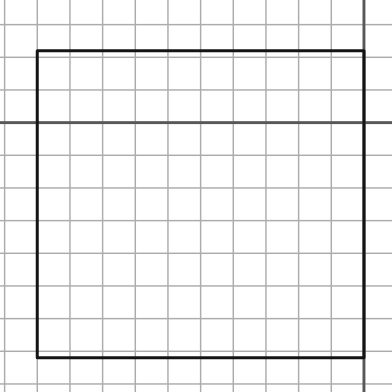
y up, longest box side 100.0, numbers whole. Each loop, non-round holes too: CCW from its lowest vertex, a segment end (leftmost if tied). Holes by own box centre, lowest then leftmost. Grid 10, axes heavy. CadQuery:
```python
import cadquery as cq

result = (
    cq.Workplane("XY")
    .moveTo(-100.0, -72.0)
    .lineTo(0.0, -72.0)
    .lineTo(0.0, 22.0)
    .lineTo(-100.0, 22.0)
    .close()
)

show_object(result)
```